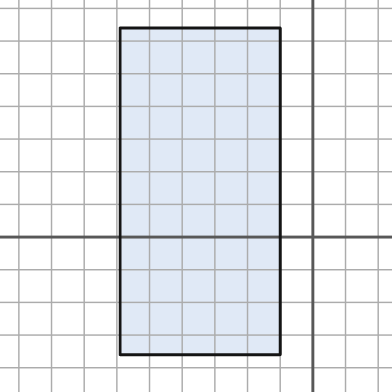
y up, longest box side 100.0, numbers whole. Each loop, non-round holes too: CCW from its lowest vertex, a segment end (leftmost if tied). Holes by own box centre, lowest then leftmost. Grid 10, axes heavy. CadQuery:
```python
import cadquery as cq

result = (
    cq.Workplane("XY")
    .moveTo(-59.0, -36.0)
    .lineTo(-10.0, -36.0)
    .lineTo(-10.0, 64.0)
    .lineTo(-59.0, 64.0)
    .close()
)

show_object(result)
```